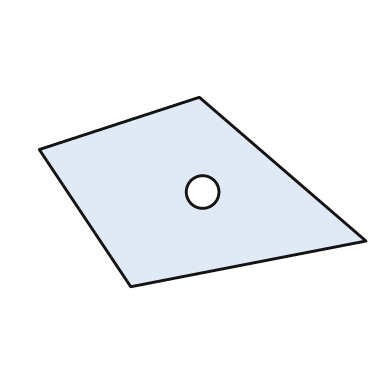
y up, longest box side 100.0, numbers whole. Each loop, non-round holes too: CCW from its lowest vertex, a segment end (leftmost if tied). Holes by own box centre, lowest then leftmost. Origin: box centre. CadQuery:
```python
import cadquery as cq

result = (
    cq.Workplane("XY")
    .moveTo(-22.0, -29.0)
    .lineTo(50.0, -15.0)
    .lineTo(-1.0, 29.0)
    .lineTo(-50.0, 13.0)
    .close()
    .moveTo(0.0, 0.0)
    .circle(5.0)
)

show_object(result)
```